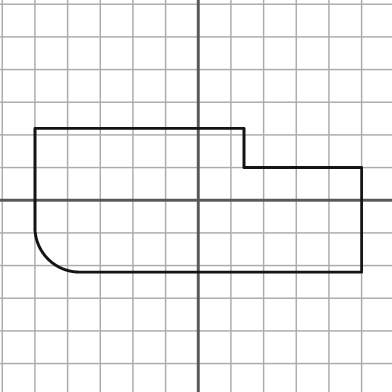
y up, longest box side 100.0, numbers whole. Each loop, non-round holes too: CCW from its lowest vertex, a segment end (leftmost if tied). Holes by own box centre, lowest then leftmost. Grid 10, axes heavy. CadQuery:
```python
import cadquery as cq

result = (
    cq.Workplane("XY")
    .moveTo(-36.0, -22.0)
    .lineTo(50.0, -22.0)
    .lineTo(50.0, 10.0)
    .lineTo(14.0, 10.0)
    .lineTo(14.0, 22.0)
    .lineTo(-50.0, 22.0)
    .lineTo(-50.0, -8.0)
    .threePointArc((-46.0, -18.0), (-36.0, -22.0))
    .close()
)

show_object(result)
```